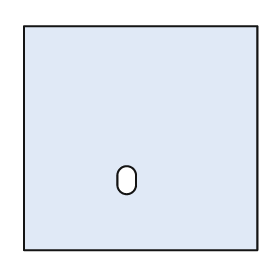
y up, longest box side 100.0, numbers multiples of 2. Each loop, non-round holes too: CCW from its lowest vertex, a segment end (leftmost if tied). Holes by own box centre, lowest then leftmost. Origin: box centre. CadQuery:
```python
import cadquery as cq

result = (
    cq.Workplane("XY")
    .moveTo(-50.0, -48.0)
    .lineTo(50.0, -48.0)
    .lineTo(50.0, 48.0)
    .lineTo(-50.0, 48.0)
    .close()
    .moveTo(-10.0, -20.0)
    .threePointArc((-6.0, -24.0), (-2.0, -20.0))
    .lineTo(-2.0, -16.0)
    .threePointArc((-6.0, -12.0), (-10.0, -16.0))
    .close()
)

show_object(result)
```